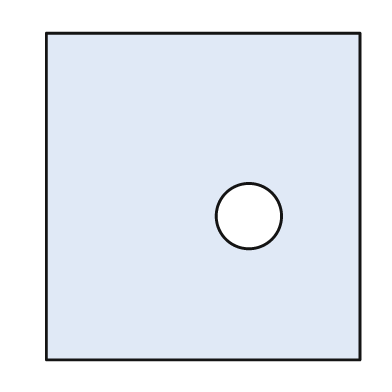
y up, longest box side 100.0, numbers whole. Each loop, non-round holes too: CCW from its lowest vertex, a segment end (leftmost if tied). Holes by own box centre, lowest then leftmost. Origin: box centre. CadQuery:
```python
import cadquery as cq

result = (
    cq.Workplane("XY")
    .moveTo(-48.0, -50.0)
    .lineTo(48.0, -50.0)
    .lineTo(48.0, 50.0)
    .lineTo(-48.0, 50.0)
    .close()
    .moveTo(14.0, -6.0)
    .circle(10.0)
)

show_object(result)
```